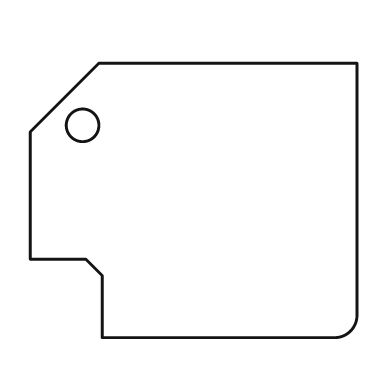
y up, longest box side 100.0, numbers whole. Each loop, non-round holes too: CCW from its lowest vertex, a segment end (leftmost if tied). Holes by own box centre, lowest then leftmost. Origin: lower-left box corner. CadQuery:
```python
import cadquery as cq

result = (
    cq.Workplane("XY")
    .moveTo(22.0, 0.0)
    .lineTo(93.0, 0.0)
    .threePointArc((98.0, 2.0), (100.0, 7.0))
    .lineTo(100.0, 84.0)
    .lineTo(21.0, 84.0)
    .lineTo(0.0, 63.0)
    .lineTo(0.0, 24.0)
    .lineTo(17.0, 24.0)
    .lineTo(22.0, 19.0)
    .close()
    .moveTo(16.0, 65.0)
    .circle(5.0)
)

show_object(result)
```